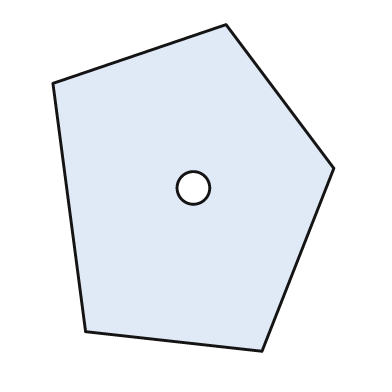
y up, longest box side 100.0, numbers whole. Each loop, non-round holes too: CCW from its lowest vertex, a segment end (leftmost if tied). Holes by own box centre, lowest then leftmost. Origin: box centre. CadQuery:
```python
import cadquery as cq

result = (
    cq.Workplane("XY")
    .moveTo(21.0, -50.0)
    .lineTo(43.0, 6.0)
    .lineTo(10.0, 50.0)
    .lineTo(-43.0, 32.0)
    .lineTo(-33.0, -44.0)
    .close()
    .moveTo(0.0, 0.0)
    .circle(5.0)
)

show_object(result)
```